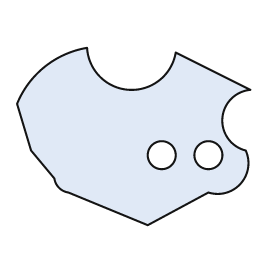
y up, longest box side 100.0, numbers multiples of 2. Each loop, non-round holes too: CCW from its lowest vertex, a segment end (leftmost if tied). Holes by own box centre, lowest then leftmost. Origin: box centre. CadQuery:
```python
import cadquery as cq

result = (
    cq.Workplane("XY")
    .moveTo(6.0, -38.0)
    .lineTo(32.0, -24.0)
    .threePointArc((46.0, -20.0), (48.0, -6.0))
    .threePointArc((38.0, 8.0), (50.0, 20.0))
    .lineTo(18.0, 36.0)
    .threePointArc((-2.0, 20.0), (-20.0, 38.0))
    .threePointArc((-38.0, 30.0), (-50.0, 14.0))
    .lineTo(-44.0, -6.0)
    .lineTo(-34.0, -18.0)
    .threePointArc((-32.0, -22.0), (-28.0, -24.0))
    .close()
    .moveTo(12.0, -8.0)
    .circle(6.0)
    .moveTo(32.0, -8.0)
    .circle(6.0)
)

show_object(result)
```